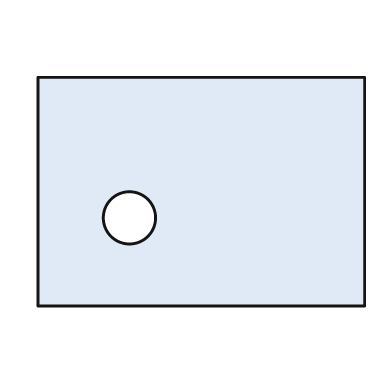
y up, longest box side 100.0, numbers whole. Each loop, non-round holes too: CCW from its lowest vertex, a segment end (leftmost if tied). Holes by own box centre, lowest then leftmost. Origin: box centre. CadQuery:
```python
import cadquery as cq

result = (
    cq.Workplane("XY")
    .moveTo(-50.0, -35.0)
    .lineTo(50.0, -35.0)
    .lineTo(50.0, 35.0)
    .lineTo(-50.0, 35.0)
    .close()
    .moveTo(-22.0, -8.0)
    .circle(8.0)
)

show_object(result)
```